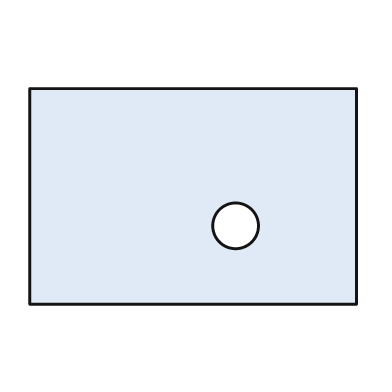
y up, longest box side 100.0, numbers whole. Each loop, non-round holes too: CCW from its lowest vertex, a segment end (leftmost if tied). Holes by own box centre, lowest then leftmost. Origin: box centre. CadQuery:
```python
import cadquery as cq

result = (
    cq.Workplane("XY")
    .moveTo(-50.0, -33.0)
    .lineTo(50.0, -33.0)
    .lineTo(50.0, 33.0)
    .lineTo(-50.0, 33.0)
    .close()
    .moveTo(13.0, -9.0)
    .circle(7.0)
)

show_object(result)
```